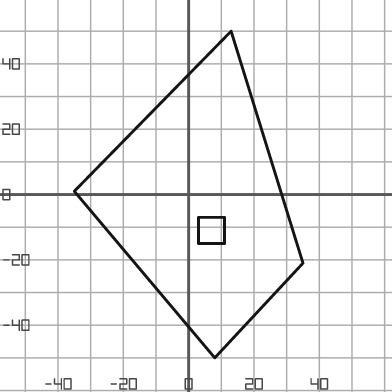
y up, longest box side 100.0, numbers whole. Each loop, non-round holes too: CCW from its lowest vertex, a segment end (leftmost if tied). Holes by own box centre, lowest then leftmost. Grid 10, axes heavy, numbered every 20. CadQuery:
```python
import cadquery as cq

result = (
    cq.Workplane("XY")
    .moveTo(8.0, -50.0)
    .lineTo(35.0, -21.0)
    .lineTo(13.0, 50.0)
    .lineTo(-35.0, 1.0)
    .close()
    .moveTo(3.0, -15.0)
    .lineTo(11.0, -15.0)
    .lineTo(11.0, -7.0)
    .lineTo(3.0, -7.0)
    .close()
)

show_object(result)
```